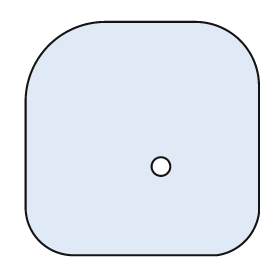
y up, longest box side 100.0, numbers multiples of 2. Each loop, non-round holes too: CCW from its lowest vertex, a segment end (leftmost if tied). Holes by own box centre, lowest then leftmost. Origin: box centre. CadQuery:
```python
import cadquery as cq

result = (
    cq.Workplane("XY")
    .moveTo(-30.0, -50.0)
    .lineTo(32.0, -50.0)
    .threePointArc((44.0, -44.0), (50.0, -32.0))
    .lineTo(50.0, 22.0)
    .threePointArc((42.0, 42.0), (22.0, 50.0))
    .lineTo(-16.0, 50.0)
    .threePointArc((-40.0, 40.0), (-50.0, 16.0))
    .lineTo(-50.0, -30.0)
    .threePointArc((-44.0, -44.0), (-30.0, -50.0))
    .close()
    .moveTo(8.0, -12.0)
    .circle(4.0)
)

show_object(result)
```